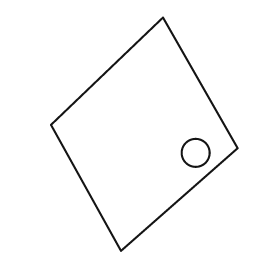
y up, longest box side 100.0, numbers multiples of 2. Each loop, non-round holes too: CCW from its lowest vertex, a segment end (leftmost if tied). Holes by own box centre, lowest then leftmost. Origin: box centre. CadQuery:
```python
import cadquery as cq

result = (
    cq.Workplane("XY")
    .moveTo(-10.0, -50.0)
    .lineTo(40.0, -6.0)
    .lineTo(8.0, 50.0)
    .lineTo(-40.0, 4.0)
    .close()
    .moveTo(22.0, -8.0)
    .circle(6.0)
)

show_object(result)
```